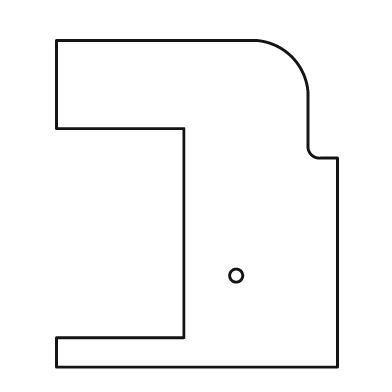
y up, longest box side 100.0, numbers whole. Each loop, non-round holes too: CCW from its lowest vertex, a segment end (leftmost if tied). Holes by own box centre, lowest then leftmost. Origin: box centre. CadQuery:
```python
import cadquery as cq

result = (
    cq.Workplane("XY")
    .moveTo(-43.0, -50.0)
    .lineTo(43.0, -50.0)
    .lineTo(43.0, 14.0)
    .lineTo(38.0, 14.0)
    .threePointArc((35.0, 15.0), (34.0, 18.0))
    .lineTo(34.0, 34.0)
    .threePointArc((29.0, 45.0), (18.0, 50.0))
    .lineTo(-43.0, 50.0)
    .lineTo(-43.0, 23.0)
    .lineTo(-4.0, 23.0)
    .lineTo(-4.0, -41.0)
    .lineTo(-43.0, -41.0)
    .close()
    .moveTo(12.0, -22.0)
    .circle(2.0)
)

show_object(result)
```